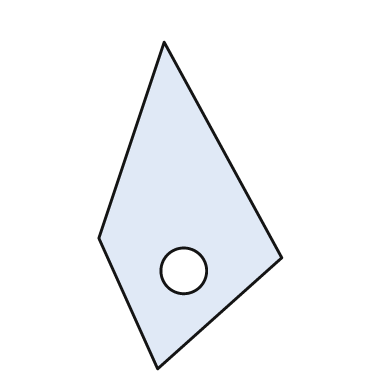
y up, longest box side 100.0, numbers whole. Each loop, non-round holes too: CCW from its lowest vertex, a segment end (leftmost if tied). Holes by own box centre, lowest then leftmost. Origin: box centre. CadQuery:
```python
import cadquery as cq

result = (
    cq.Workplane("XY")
    .moveTo(-10.0, -50.0)
    .lineTo(28.0, -16.0)
    .lineTo(-8.0, 50.0)
    .lineTo(-28.0, -10.0)
    .close()
    .moveTo(-2.0, -20.0)
    .circle(7.0)
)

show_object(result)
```